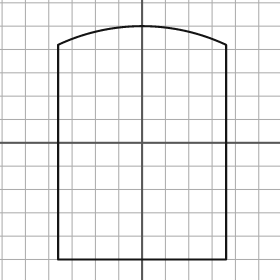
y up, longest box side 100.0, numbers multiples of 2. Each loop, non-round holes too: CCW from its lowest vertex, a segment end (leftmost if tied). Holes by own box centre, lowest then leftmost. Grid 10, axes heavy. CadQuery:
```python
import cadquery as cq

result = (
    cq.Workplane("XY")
    .moveTo(-36.0, -50.0)
    .lineTo(36.0, -50.0)
    .lineTo(36.0, 42.0)
    .threePointArc((0.0, 50.0), (-36.0, 42.0))
    .close()
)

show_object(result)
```